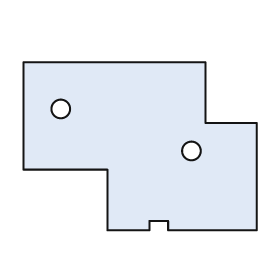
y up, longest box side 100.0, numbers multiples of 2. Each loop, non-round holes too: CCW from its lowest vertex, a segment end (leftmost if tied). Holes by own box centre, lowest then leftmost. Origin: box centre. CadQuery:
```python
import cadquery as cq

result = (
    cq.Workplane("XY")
    .moveTo(-14.0, -36.0)
    .lineTo(4.0, -36.0)
    .lineTo(4.0, -32.0)
    .lineTo(12.0, -32.0)
    .lineTo(12.0, -36.0)
    .lineTo(50.0, -36.0)
    .lineTo(50.0, 10.0)
    .lineTo(28.0, 10.0)
    .lineTo(28.0, 36.0)
    .lineTo(-50.0, 36.0)
    .lineTo(-50.0, -10.0)
    .lineTo(-14.0, -10.0)
    .close()
    .moveTo(22.0, -2.0)
    .circle(4.0)
    .moveTo(-34.0, 16.0)
    .circle(4.0)
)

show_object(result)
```